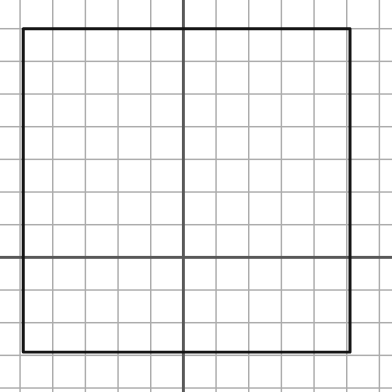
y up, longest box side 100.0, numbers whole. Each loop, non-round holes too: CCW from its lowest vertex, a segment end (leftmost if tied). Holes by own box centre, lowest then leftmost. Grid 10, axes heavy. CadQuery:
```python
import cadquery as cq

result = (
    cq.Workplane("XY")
    .moveTo(-49.0, -29.0)
    .lineTo(51.0, -29.0)
    .lineTo(51.0, 70.0)
    .lineTo(-49.0, 70.0)
    .close()
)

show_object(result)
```